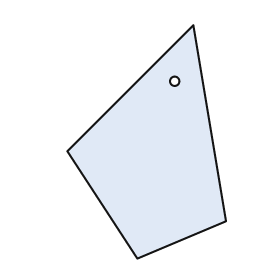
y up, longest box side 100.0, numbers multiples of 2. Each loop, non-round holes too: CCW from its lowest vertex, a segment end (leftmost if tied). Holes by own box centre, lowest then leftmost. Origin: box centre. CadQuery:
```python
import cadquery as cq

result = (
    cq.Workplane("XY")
    .moveTo(-4.0, -50.0)
    .lineTo(34.0, -34.0)
    .lineTo(20.0, 50.0)
    .lineTo(-34.0, -4.0)
    .close()
    .moveTo(12.0, 26.0)
    .circle(2.0)
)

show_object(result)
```